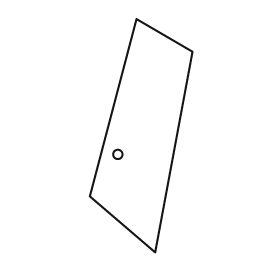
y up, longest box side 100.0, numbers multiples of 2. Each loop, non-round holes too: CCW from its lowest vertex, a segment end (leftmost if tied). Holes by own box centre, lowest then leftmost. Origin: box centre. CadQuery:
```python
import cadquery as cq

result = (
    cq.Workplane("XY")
    .moveTo(6.0, -50.0)
    .lineTo(22.0, 36.0)
    .lineTo(-2.0, 50.0)
    .lineTo(-22.0, -26.0)
    .close()
    .moveTo(-10.0, -8.0)
    .circle(2.0)
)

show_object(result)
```